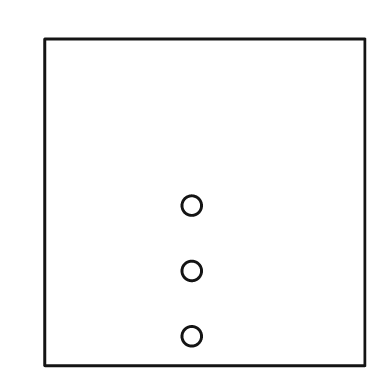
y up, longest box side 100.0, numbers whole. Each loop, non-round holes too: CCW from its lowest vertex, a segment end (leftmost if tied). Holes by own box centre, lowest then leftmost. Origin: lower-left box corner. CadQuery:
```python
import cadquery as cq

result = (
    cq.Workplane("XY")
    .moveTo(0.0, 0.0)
    .lineTo(98.0, 0.0)
    .lineTo(98.0, 100.0)
    .lineTo(0.0, 100.0)
    .close()
    .moveTo(45.0, 9.0)
    .circle(3.0)
    .moveTo(45.0, 29.0)
    .circle(3.0)
    .moveTo(45.0, 49.0)
    .circle(3.0)
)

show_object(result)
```